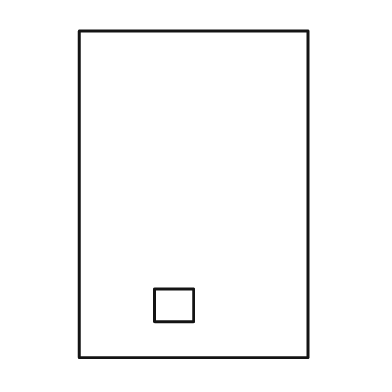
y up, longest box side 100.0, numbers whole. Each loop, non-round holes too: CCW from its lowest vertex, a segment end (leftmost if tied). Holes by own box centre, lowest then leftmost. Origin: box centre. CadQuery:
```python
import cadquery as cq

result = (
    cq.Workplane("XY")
    .moveTo(-35.0, -50.0)
    .lineTo(35.0, -50.0)
    .lineTo(35.0, 50.0)
    .lineTo(-35.0, 50.0)
    .close()
    .moveTo(-12.0, -39.0)
    .lineTo(0.0, -39.0)
    .lineTo(0.0, -29.0)
    .lineTo(-12.0, -29.0)
    .close()
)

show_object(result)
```